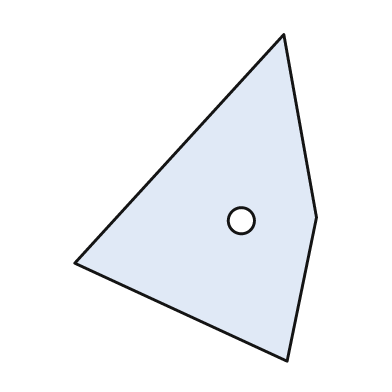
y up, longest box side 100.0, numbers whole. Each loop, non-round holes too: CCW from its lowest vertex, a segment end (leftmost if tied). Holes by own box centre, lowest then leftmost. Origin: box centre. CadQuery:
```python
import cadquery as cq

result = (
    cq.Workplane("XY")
    .moveTo(28.0, -50.0)
    .lineTo(37.0, -6.0)
    .lineTo(27.0, 50.0)
    .lineTo(-37.0, -20.0)
    .close()
    .moveTo(14.0, -7.0)
    .circle(4.0)
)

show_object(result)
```